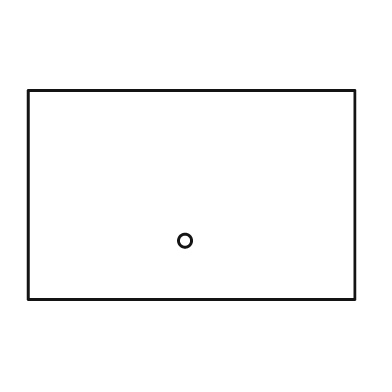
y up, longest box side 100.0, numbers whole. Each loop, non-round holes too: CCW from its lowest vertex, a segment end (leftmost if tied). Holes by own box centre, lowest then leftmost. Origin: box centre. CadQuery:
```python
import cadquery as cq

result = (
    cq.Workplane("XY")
    .moveTo(-50.0, -32.0)
    .lineTo(50.0, -32.0)
    .lineTo(50.0, 32.0)
    .lineTo(-50.0, 32.0)
    .close()
    .moveTo(-2.0, -14.0)
    .circle(2.0)
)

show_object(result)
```